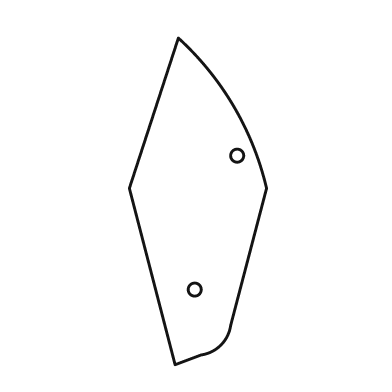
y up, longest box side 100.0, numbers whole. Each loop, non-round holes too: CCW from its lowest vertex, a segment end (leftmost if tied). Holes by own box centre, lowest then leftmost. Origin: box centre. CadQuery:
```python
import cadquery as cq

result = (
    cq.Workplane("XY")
    .moveTo(-7.0, -50.0)
    .lineTo(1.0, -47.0)
    .threePointArc((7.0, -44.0), (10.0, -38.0))
    .lineTo(21.0, 4.0)
    .threePointArc((11.0, 29.0), (-6.0, 50.0))
    .lineTo(-21.0, 4.0)
    .close()
    .moveTo(-1.0, -27.0)
    .circle(2.0)
    .moveTo(12.0, 14.0)
    .circle(2.0)
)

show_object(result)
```